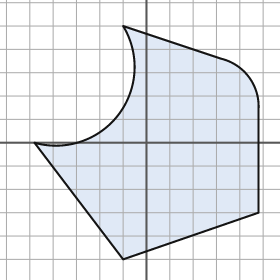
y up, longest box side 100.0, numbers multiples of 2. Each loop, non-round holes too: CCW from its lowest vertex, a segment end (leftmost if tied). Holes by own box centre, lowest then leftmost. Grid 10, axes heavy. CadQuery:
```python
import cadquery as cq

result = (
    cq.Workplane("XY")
    .moveTo(-10.0, -50.0)
    .lineTo(48.0, -30.0)
    .lineTo(48.0, 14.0)
    .threePointArc((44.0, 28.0), (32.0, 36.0))
    .lineTo(-10.0, 50.0)
    .threePointArc((-12.0, 12.0), (-48.0, 0.0))
    .close()
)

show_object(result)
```